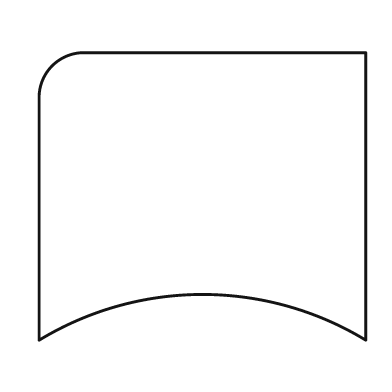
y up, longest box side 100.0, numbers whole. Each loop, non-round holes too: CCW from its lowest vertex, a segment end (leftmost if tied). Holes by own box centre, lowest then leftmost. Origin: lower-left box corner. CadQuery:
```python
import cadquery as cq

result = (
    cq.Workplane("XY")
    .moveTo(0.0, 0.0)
    .threePointArc((50.0, 14.0), (100.0, 0.0))
    .lineTo(100.0, 88.0)
    .lineTo(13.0, 88.0)
    .threePointArc((4.0, 84.0), (0.0, 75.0))
    .close()
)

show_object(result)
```